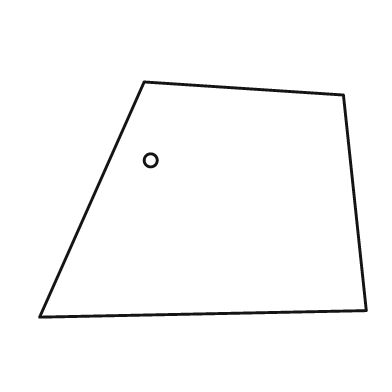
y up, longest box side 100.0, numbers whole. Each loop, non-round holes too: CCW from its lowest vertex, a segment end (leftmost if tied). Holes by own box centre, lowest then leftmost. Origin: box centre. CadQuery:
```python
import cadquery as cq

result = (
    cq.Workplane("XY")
    .moveTo(-50.0, -36.0)
    .lineTo(50.0, -34.0)
    .lineTo(43.0, 32.0)
    .lineTo(-18.0, 36.0)
    .close()
    .moveTo(-16.0, 12.0)
    .circle(2.0)
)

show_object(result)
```